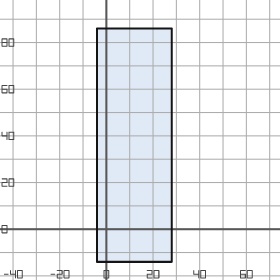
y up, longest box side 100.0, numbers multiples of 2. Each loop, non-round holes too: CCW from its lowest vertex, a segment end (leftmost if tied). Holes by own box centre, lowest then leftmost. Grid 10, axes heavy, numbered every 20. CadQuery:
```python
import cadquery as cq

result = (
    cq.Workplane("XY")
    .moveTo(-4.0, -14.0)
    .lineTo(28.0, -14.0)
    .lineTo(28.0, 86.0)
    .lineTo(-4.0, 86.0)
    .close()
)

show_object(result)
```